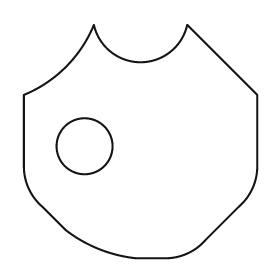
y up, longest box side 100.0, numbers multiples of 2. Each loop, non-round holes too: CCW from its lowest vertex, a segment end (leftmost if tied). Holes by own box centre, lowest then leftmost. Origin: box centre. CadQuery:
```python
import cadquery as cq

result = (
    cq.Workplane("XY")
    .moveTo(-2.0, -50.0)
    .lineTo(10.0, -50.0)
    .threePointArc((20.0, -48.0), (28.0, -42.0))
    .lineTo(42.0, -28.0)
    .threePointArc((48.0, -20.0), (50.0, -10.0))
    .lineTo(50.0, 20.0)
    .lineTo(20.0, 50.0)
    .threePointArc((0.0, 34.0), (-20.0, 50.0))
    .threePointArc((-32.0, 32.0), (-50.0, 20.0))
    .lineTo(-50.0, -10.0)
    .threePointArc((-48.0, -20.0), (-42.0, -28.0))
    .lineTo(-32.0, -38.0)
    .threePointArc((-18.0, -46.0), (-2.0, -50.0))
    .close()
    .moveTo(-24.0, -2.0)
    .circle(12.0)
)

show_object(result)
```